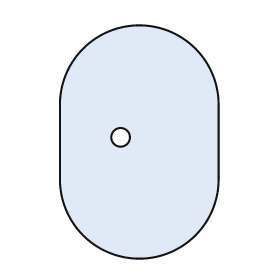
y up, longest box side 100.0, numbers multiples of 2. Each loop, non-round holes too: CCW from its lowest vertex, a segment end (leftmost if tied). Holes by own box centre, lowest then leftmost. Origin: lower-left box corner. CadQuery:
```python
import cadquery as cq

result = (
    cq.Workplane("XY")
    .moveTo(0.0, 34.0)
    .threePointArc((34.0, 0.0), (68.0, 34.0))
    .lineTo(68.0, 66.0)
    .threePointArc((34.0, 100.0), (0.0, 66.0))
    .close()
    .moveTo(26.0, 52.0)
    .circle(4.0)
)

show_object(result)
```